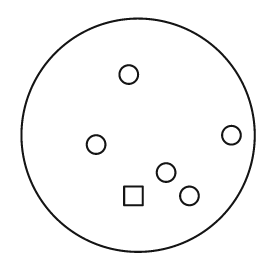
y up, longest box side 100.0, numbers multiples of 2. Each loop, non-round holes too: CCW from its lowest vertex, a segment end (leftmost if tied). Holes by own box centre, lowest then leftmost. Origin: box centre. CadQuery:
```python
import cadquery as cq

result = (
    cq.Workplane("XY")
    .moveTo(0.0, 0.0)
    .circle(50.0)
    .moveTo(-6.0, -30.0)
    .lineTo(2.0, -30.0)
    .lineTo(2.0, -22.0)
    .lineTo(-6.0, -22.0)
    .close()
    .moveTo(22.0, -26.0)
    .circle(4.0)
    .moveTo(12.0, -16.0)
    .circle(4.0)
    .moveTo(-18.0, -4.0)
    .circle(4.0)
    .moveTo(40.0, 0.0)
    .circle(4.0)
    .moveTo(-4.0, 26.0)
    .circle(4.0)
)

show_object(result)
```